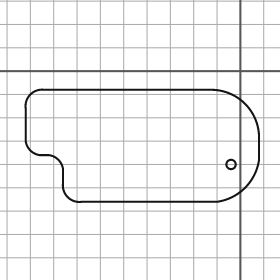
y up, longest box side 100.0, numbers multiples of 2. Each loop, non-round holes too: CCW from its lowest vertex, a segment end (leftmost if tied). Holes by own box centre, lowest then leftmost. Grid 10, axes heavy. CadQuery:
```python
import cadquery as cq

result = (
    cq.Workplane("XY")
    .moveTo(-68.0, -56.0)
    .lineTo(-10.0, -56.0)
    .threePointArc((2.0, -50.0), (8.0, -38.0))
    .lineTo(8.0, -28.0)
    .threePointArc((2.0, -14.0), (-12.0, -8.0))
    .lineTo(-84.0, -8.0)
    .threePointArc((-90.0, -10.0), (-92.0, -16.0))
    .lineTo(-92.0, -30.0)
    .threePointArc((-90.0, -34.0), (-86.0, -36.0))
    .lineTo(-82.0, -36.0)
    .threePointArc((-78.0, -38.0), (-76.0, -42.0))
    .lineTo(-76.0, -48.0)
    .threePointArc((-74.0, -54.0), (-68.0, -56.0))
    .close()
    .moveTo(-4.0, -40.0)
    .circle(2.0)
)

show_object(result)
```